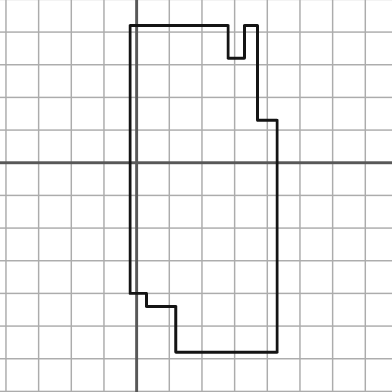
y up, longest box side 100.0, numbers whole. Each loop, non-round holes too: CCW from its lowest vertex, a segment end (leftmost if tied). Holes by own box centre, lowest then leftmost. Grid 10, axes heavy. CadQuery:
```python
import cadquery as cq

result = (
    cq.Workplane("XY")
    .moveTo(12.0, -58.0)
    .lineTo(43.0, -58.0)
    .lineTo(43.0, 13.0)
    .lineTo(37.0, 13.0)
    .lineTo(37.0, 42.0)
    .lineTo(33.0, 42.0)
    .lineTo(33.0, 32.0)
    .lineTo(28.0, 32.0)
    .lineTo(28.0, 42.0)
    .lineTo(-2.0, 42.0)
    .lineTo(-2.0, -40.0)
    .lineTo(3.0, -40.0)
    .lineTo(3.0, -44.0)
    .lineTo(12.0, -44.0)
    .close()
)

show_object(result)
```